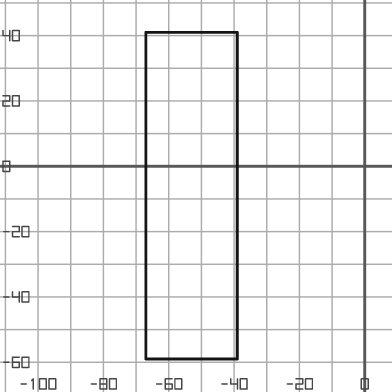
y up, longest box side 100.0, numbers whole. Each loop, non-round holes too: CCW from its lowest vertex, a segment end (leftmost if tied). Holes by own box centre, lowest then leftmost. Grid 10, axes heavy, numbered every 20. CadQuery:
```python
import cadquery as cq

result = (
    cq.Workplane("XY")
    .moveTo(-67.0, -59.0)
    .lineTo(-39.0, -59.0)
    .lineTo(-39.0, 41.0)
    .lineTo(-67.0, 41.0)
    .close()
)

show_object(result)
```